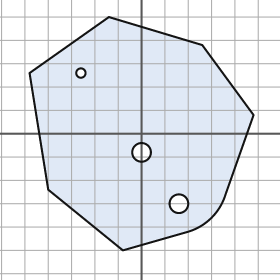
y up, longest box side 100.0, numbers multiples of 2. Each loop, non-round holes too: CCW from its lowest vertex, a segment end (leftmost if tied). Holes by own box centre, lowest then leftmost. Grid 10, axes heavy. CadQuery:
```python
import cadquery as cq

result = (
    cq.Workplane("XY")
    .moveTo(-8.0, -50.0)
    .lineTo(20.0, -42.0)
    .threePointArc((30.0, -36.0), (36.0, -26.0))
    .lineTo(48.0, 8.0)
    .lineTo(26.0, 38.0)
    .lineTo(-14.0, 50.0)
    .lineTo(-48.0, 26.0)
    .lineTo(-40.0, -24.0)
    .close()
    .moveTo(16.0, -30.0)
    .circle(4.0)
    .moveTo(0.0, -8.0)
    .circle(4.0)
    .moveTo(-26.0, 26.0)
    .circle(2.0)
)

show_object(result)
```